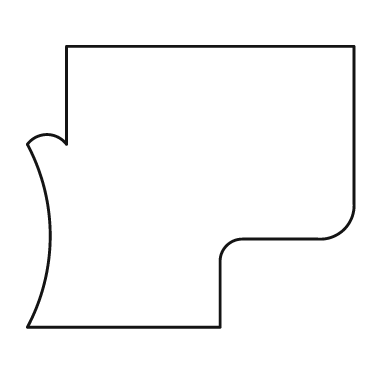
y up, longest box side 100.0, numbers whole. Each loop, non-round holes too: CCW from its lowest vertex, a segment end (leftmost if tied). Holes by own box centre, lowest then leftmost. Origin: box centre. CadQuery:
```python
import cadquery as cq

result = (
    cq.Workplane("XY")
    .moveTo(-50.0, -43.0)
    .lineTo(9.0, -43.0)
    .lineTo(9.0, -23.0)
    .threePointArc((11.0, -18.0), (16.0, -16.0))
    .lineTo(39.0, -16.0)
    .threePointArc((47.0, -13.0), (50.0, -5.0))
    .lineTo(50.0, 43.0)
    .lineTo(-38.0, 43.0)
    .lineTo(-38.0, 13.0)
    .threePointArc((-44.0, 16.0), (-50.0, 13.0))
    .threePointArc((-43.0, -15.0), (-50.0, -43.0))
    .close()
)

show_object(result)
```